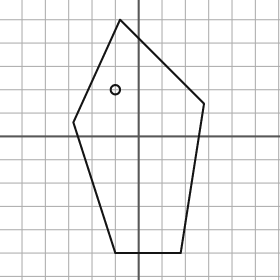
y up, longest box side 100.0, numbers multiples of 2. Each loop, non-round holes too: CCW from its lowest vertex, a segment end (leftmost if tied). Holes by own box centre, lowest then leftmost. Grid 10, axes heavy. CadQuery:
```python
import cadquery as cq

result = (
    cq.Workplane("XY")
    .moveTo(-10.0, -50.0)
    .lineTo(18.0, -50.0)
    .lineTo(28.0, 14.0)
    .lineTo(-8.0, 50.0)
    .lineTo(-28.0, 6.0)
    .close()
    .moveTo(-10.0, 20.0)
    .circle(2.0)
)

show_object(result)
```